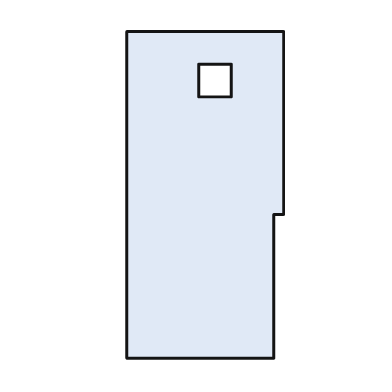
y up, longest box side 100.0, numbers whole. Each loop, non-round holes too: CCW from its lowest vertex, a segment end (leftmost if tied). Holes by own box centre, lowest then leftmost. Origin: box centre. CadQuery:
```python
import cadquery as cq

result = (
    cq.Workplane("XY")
    .moveTo(-24.0, -50.0)
    .lineTo(21.0, -50.0)
    .lineTo(21.0, -6.0)
    .lineTo(24.0, -6.0)
    .lineTo(24.0, 50.0)
    .lineTo(-24.0, 50.0)
    .close()
    .moveTo(-2.0, 30.0)
    .lineTo(8.0, 30.0)
    .lineTo(8.0, 40.0)
    .lineTo(-2.0, 40.0)
    .close()
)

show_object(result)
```